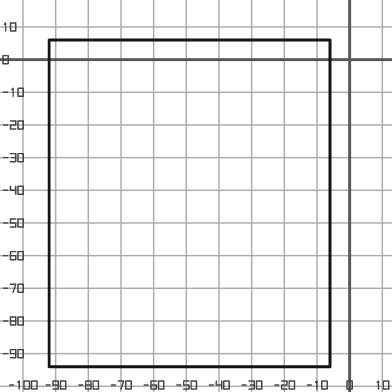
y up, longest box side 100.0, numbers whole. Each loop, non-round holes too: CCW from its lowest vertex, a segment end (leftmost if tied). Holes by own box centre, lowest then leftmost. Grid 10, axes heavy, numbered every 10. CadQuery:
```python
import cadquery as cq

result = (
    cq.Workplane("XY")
    .moveTo(-92.0, -94.0)
    .lineTo(-6.0, -94.0)
    .lineTo(-6.0, 6.0)
    .lineTo(-92.0, 6.0)
    .close()
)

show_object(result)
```